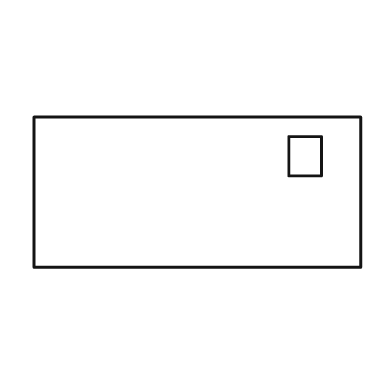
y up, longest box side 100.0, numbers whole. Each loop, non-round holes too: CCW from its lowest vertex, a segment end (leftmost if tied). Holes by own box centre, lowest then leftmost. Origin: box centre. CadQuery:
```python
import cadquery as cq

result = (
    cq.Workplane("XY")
    .moveTo(-50.0, -23.0)
    .lineTo(50.0, -23.0)
    .lineTo(50.0, 23.0)
    .lineTo(-50.0, 23.0)
    .close()
    .moveTo(28.0, 5.0)
    .lineTo(38.0, 5.0)
    .lineTo(38.0, 17.0)
    .lineTo(28.0, 17.0)
    .close()
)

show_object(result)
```